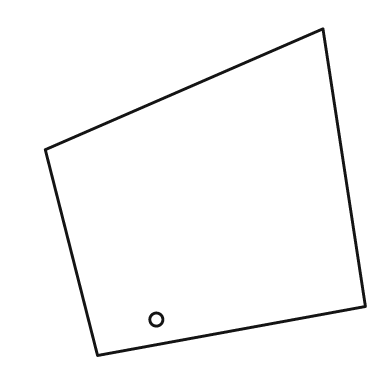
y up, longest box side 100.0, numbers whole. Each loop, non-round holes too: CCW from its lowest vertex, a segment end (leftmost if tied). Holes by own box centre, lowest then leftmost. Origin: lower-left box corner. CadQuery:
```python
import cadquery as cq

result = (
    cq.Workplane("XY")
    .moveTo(16.0, 0.0)
    .lineTo(98.0, 15.0)
    .lineTo(85.0, 100.0)
    .lineTo(0.0, 63.0)
    .close()
    .moveTo(34.0, 11.0)
    .circle(2.0)
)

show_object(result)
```